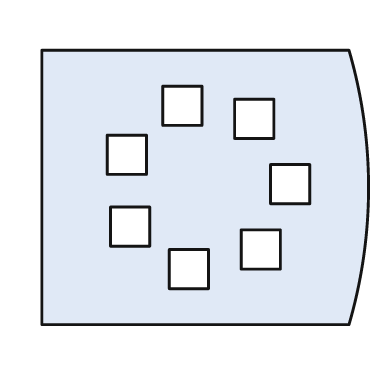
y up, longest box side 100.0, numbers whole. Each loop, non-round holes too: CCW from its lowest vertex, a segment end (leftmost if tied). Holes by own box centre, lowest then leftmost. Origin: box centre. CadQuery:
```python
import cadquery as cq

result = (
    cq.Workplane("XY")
    .moveTo(-50.0, -42.0)
    .lineTo(44.0, -42.0)
    .threePointArc((50.0, 0.0), (44.0, 42.0))
    .lineTo(-50.0, 42.0)
    .close()
    .moveTo(-11.0, -31.0)
    .lineTo(1.0, -31.0)
    .lineTo(1.0, -19.0)
    .lineTo(-11.0, -19.0)
    .close()
    .moveTo(11.0, -25.0)
    .lineTo(23.0, -25.0)
    .lineTo(23.0, -13.0)
    .lineTo(11.0, -13.0)
    .close()
    .moveTo(-29.0, -18.0)
    .lineTo(-17.0, -18.0)
    .lineTo(-17.0, -6.0)
    .lineTo(-29.0, -6.0)
    .close()
    .moveTo(20.0, -5.0)
    .lineTo(32.0, -5.0)
    .lineTo(32.0, 7.0)
    .lineTo(20.0, 7.0)
    .close()
    .moveTo(-30.0, 4.0)
    .lineTo(-18.0, 4.0)
    .lineTo(-18.0, 16.0)
    .lineTo(-30.0, 16.0)
    .close()
    .moveTo(9.0, 15.0)
    .lineTo(21.0, 15.0)
    .lineTo(21.0, 27.0)
    .lineTo(9.0, 27.0)
    .close()
    .moveTo(-13.0, 19.0)
    .lineTo(-1.0, 19.0)
    .lineTo(-1.0, 31.0)
    .lineTo(-13.0, 31.0)
    .close()
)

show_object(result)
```